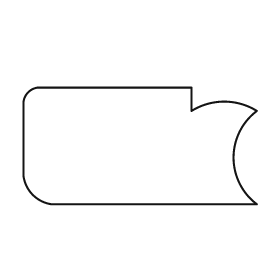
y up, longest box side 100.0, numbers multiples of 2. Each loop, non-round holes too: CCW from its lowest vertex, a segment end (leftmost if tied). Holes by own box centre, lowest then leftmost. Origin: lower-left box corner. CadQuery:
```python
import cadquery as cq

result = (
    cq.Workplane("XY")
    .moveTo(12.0, 0.0)
    .lineTo(100.0, 0.0)
    .threePointArc((90.0, 20.0), (100.0, 40.0))
    .threePointArc((86.0, 44.0), (72.0, 40.0))
    .lineTo(72.0, 50.0)
    .lineTo(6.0, 50.0)
    .threePointArc((2.0, 48.0), (0.0, 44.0))
    .lineTo(0.0, 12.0)
    .threePointArc((4.0, 4.0), (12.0, 0.0))
    .close()
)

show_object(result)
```